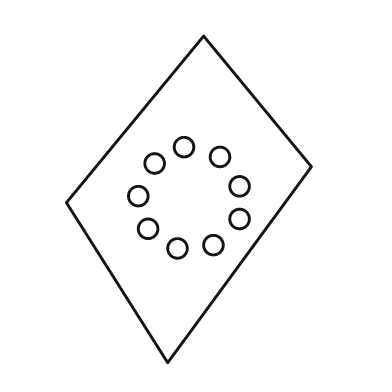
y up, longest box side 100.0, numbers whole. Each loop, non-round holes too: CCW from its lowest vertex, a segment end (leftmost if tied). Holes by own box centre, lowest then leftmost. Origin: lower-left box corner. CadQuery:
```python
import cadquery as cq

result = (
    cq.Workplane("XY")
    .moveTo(31.0, 0.0)
    .lineTo(75.0, 60.0)
    .lineTo(42.0, 100.0)
    .lineTo(0.0, 49.0)
    .close()
    .moveTo(34.0, 35.0)
    .circle(3.0)
    .moveTo(45.0, 36.0)
    .circle(3.0)
    .moveTo(25.0, 41.0)
    .circle(3.0)
    .moveTo(53.0, 44.0)
    .circle(3.0)
    .moveTo(22.0, 51.0)
    .circle(3.0)
    .moveTo(53.0, 54.0)
    .circle(3.0)
    .moveTo(27.0, 61.0)
    .circle(3.0)
    .moveTo(47.0, 63.0)
    .circle(3.0)
    .moveTo(36.0, 66.0)
    .circle(3.0)
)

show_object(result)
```